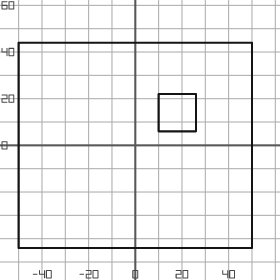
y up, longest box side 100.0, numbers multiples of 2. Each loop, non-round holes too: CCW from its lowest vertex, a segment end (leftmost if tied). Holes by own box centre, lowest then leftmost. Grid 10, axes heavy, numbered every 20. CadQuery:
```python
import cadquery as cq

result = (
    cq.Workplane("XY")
    .moveTo(-50.0, -44.0)
    .lineTo(50.0, -44.0)
    .lineTo(50.0, 44.0)
    .lineTo(-50.0, 44.0)
    .close()
    .moveTo(10.0, 6.0)
    .lineTo(26.0, 6.0)
    .lineTo(26.0, 22.0)
    .lineTo(10.0, 22.0)
    .close()
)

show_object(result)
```